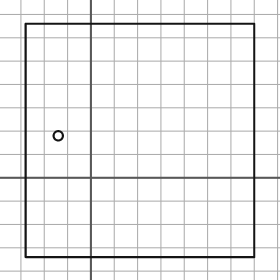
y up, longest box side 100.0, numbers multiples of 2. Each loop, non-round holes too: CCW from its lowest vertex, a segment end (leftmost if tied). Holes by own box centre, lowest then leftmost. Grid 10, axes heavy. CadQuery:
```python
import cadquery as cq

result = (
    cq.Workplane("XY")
    .moveTo(-28.0, -34.0)
    .lineTo(70.0, -34.0)
    .lineTo(70.0, 66.0)
    .lineTo(-28.0, 66.0)
    .close()
    .moveTo(-14.0, 18.0)
    .circle(2.0)
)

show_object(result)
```